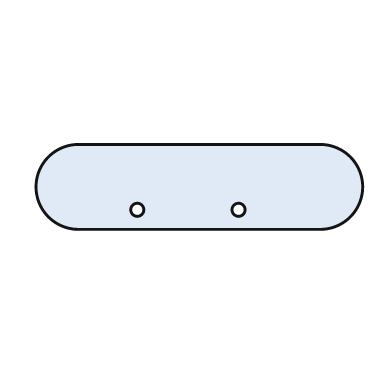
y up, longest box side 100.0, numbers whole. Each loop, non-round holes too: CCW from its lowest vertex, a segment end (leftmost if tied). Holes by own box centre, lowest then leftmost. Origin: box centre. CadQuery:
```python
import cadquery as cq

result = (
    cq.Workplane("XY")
    .moveTo(-37.0, -13.0)
    .lineTo(37.0, -13.0)
    .threePointArc((50.0, 0.0), (37.0, 13.0))
    .lineTo(-37.0, 13.0)
    .threePointArc((-50.0, 0.0), (-37.0, -13.0))
    .close()
    .moveTo(-19.0, -7.0)
    .circle(2.0)
    .moveTo(12.0, -7.0)
    .circle(2.0)
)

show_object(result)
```